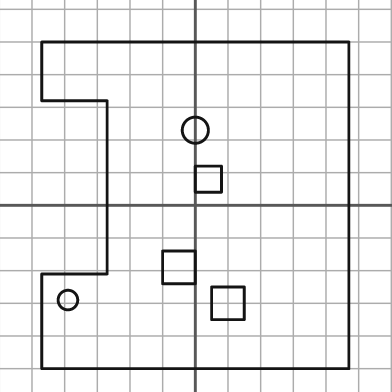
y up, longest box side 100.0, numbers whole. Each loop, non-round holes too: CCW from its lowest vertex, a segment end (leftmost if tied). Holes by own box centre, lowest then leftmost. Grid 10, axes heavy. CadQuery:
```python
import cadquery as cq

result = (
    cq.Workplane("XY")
    .moveTo(-47.0, -50.0)
    .lineTo(47.0, -50.0)
    .lineTo(47.0, 50.0)
    .lineTo(-47.0, 50.0)
    .lineTo(-47.0, 32.0)
    .lineTo(-27.0, 32.0)
    .lineTo(-27.0, -21.0)
    .lineTo(-47.0, -21.0)
    .close()
    .moveTo(5.0, -35.0)
    .lineTo(15.0, -35.0)
    .lineTo(15.0, -25.0)
    .lineTo(5.0, -25.0)
    .close()
    .moveTo(-39.0, -29.0)
    .circle(3.0)
    .moveTo(-10.0, -24.0)
    .lineTo(0.0, -24.0)
    .lineTo(0.0, -14.0)
    .lineTo(-10.0, -14.0)
    .close()
    .moveTo(0.0, 4.0)
    .lineTo(8.0, 4.0)
    .lineTo(8.0, 12.0)
    .lineTo(0.0, 12.0)
    .close()
    .moveTo(0.0, 23.0)
    .circle(4.0)
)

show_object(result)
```